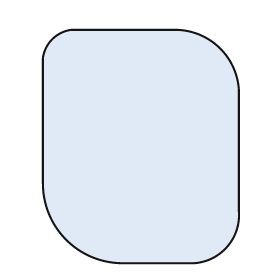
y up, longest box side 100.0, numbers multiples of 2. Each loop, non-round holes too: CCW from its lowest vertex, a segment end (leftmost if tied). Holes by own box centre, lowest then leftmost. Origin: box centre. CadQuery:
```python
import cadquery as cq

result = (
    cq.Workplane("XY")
    .moveTo(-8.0, -50.0)
    .lineTo(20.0, -50.0)
    .threePointArc((36.0, -44.0), (42.0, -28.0))
    .lineTo(42.0, 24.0)
    .threePointArc((34.0, 42.0), (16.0, 50.0))
    .lineTo(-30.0, 50.0)
    .threePointArc((-38.0, 46.0), (-42.0, 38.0))
    .lineTo(-42.0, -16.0)
    .threePointArc((-32.0, -40.0), (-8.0, -50.0))
    .close()
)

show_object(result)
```